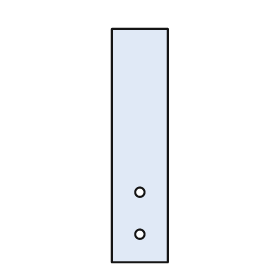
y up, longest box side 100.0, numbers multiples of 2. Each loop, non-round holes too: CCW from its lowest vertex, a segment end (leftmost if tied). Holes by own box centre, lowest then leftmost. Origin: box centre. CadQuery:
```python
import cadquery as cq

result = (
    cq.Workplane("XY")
    .moveTo(-12.0, -50.0)
    .lineTo(12.0, -50.0)
    .lineTo(12.0, 50.0)
    .lineTo(-12.0, 50.0)
    .close()
    .moveTo(0.0, -38.0)
    .circle(2.0)
    .moveTo(0.0, -20.0)
    .circle(2.0)
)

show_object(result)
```